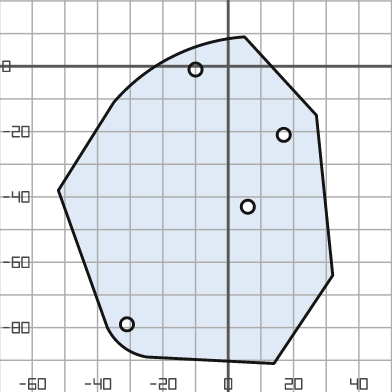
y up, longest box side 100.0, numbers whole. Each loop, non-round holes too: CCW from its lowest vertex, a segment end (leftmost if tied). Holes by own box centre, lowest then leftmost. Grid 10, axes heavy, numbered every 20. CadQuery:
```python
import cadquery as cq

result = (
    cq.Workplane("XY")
    .moveTo(14.0, -91.0)
    .lineTo(32.0, -64.0)
    .lineTo(27.0, -15.0)
    .lineTo(5.0, 9.0)
    .threePointArc((-17.0, 3.0), (-35.0, -11.0))
    .lineTo(-52.0, -38.0)
    .lineTo(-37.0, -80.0)
    .threePointArc((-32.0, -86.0), (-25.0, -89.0))
    .close()
    .moveTo(-31.0, -79.0)
    .circle(2.0)
    .moveTo(6.0, -43.0)
    .circle(2.0)
    .moveTo(17.0, -21.0)
    .circle(2.0)
    .moveTo(-10.0, -1.0)
    .circle(2.0)
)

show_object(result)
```